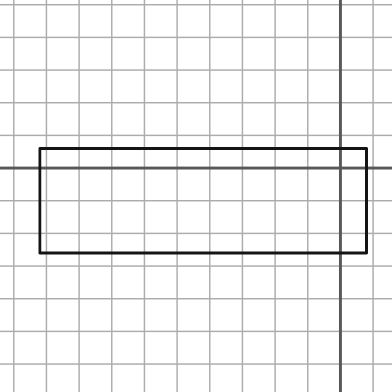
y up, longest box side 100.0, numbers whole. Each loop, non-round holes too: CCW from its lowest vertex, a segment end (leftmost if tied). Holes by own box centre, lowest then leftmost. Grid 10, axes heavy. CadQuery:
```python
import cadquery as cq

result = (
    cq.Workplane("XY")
    .moveTo(-92.0, -26.0)
    .lineTo(8.0, -26.0)
    .lineTo(8.0, 6.0)
    .lineTo(-92.0, 6.0)
    .close()
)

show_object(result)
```